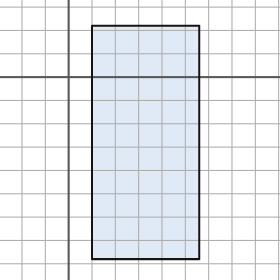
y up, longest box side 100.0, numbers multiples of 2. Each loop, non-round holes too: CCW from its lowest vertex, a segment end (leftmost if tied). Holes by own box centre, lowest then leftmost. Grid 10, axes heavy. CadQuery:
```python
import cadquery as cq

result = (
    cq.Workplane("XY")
    .moveTo(10.0, -78.0)
    .lineTo(56.0, -78.0)
    .lineTo(56.0, 22.0)
    .lineTo(10.0, 22.0)
    .close()
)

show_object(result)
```